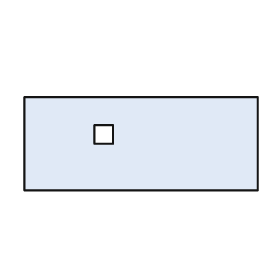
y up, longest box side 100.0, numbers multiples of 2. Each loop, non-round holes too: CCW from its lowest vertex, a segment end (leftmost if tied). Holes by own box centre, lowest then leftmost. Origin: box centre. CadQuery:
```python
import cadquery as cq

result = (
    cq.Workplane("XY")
    .moveTo(-50.0, -20.0)
    .lineTo(50.0, -20.0)
    .lineTo(50.0, 20.0)
    .lineTo(-50.0, 20.0)
    .close()
    .moveTo(-20.0, 0.0)
    .lineTo(-12.0, 0.0)
    .lineTo(-12.0, 8.0)
    .lineTo(-20.0, 8.0)
    .close()
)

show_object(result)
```